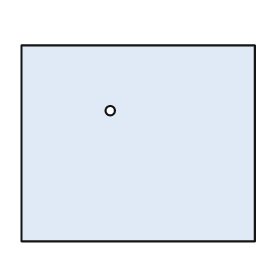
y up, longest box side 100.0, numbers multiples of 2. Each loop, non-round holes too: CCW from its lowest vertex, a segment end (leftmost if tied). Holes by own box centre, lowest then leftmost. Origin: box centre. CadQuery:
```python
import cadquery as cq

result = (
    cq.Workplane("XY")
    .moveTo(-50.0, -42.0)
    .lineTo(50.0, -42.0)
    .lineTo(50.0, 42.0)
    .lineTo(-50.0, 42.0)
    .close()
    .moveTo(-12.0, 14.0)
    .circle(2.0)
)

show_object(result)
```